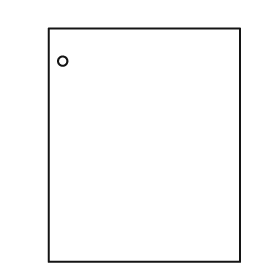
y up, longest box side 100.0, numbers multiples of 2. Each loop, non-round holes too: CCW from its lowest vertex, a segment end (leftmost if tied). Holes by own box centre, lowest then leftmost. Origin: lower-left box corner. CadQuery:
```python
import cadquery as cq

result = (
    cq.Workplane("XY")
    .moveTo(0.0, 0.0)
    .lineTo(82.0, 0.0)
    .lineTo(82.0, 100.0)
    .lineTo(0.0, 100.0)
    .close()
    .moveTo(6.0, 86.0)
    .circle(2.0)
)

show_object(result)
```